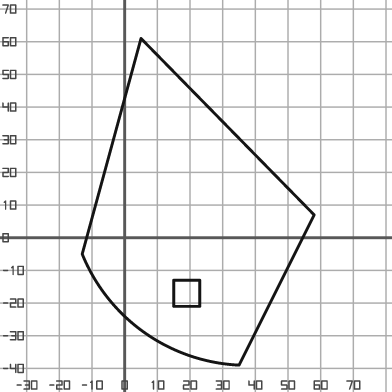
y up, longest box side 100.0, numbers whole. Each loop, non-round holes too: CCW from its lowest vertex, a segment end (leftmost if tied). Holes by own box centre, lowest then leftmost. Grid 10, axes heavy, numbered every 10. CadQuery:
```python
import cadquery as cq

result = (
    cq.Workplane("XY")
    .moveTo(35.0, -39.0)
    .lineTo(58.0, 7.0)
    .lineTo(5.0, 61.0)
    .lineTo(-13.0, -5.0)
    .threePointArc((6.0, -29.0), (35.0, -39.0))
    .close()
    .moveTo(15.0, -21.0)
    .lineTo(23.0, -21.0)
    .lineTo(23.0, -13.0)
    .lineTo(15.0, -13.0)
    .close()
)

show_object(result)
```